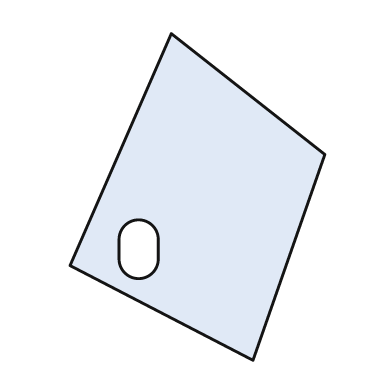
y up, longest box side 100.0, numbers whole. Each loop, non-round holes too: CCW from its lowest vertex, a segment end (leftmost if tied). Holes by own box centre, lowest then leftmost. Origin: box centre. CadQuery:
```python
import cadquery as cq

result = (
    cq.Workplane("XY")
    .moveTo(17.0, -50.0)
    .lineTo(39.0, 13.0)
    .lineTo(-8.0, 50.0)
    .lineTo(-39.0, -21.0)
    .close()
    .moveTo(-24.0, -19.0)
    .threePointArc((-18.0, -25.0), (-12.0, -19.0))
    .lineTo(-12.0, -13.0)
    .threePointArc((-18.0, -7.0), (-24.0, -13.0))
    .close()
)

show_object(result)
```